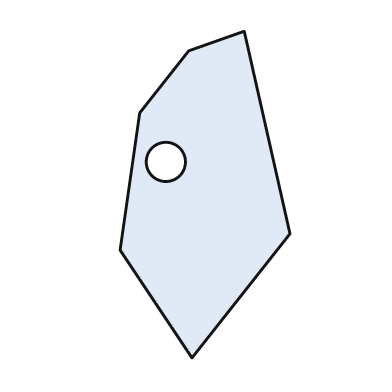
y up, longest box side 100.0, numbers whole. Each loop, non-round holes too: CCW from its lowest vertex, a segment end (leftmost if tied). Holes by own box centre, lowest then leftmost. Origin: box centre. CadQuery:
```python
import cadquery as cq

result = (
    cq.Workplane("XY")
    .moveTo(-4.0, -50.0)
    .lineTo(26.0, -12.0)
    .lineTo(12.0, 50.0)
    .lineTo(-5.0, 44.0)
    .lineTo(-20.0, 25.0)
    .lineTo(-26.0, -17.0)
    .close()
    .moveTo(-12.0, 10.0)
    .circle(6.0)
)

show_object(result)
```